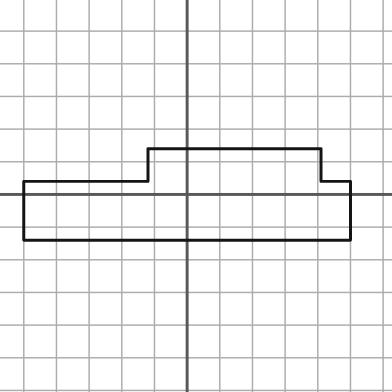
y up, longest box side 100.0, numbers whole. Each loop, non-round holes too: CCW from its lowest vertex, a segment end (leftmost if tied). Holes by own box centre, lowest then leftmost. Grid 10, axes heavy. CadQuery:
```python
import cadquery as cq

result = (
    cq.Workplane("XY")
    .moveTo(-50.0, -14.0)
    .lineTo(50.0, -14.0)
    .lineTo(50.0, 4.0)
    .lineTo(41.0, 4.0)
    .lineTo(41.0, 14.0)
    .lineTo(-12.0, 14.0)
    .lineTo(-12.0, 4.0)
    .lineTo(-50.0, 4.0)
    .close()
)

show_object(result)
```